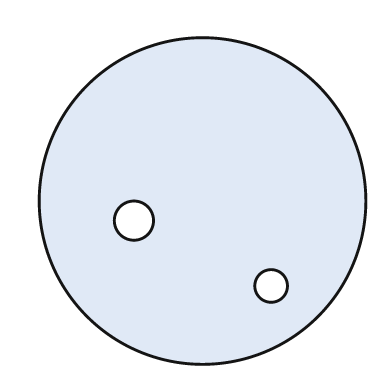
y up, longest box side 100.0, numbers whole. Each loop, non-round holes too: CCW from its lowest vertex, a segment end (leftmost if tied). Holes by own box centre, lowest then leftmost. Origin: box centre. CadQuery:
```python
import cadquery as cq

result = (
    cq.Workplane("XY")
    .moveTo(0.0, 0.0)
    .circle(50.0)
    .moveTo(21.0, -26.0)
    .circle(5.0)
    .moveTo(-21.0, -6.0)
    .circle(6.0)
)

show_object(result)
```